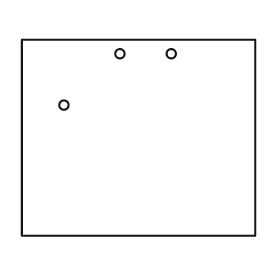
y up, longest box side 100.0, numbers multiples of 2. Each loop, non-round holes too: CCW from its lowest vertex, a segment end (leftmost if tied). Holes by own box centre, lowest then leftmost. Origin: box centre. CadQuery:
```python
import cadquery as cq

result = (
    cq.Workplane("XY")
    .moveTo(-50.0, -42.0)
    .lineTo(50.0, -42.0)
    .lineTo(50.0, 42.0)
    .lineTo(-50.0, 42.0)
    .close()
    .moveTo(-32.0, 14.0)
    .circle(2.0)
    .moveTo(-8.0, 36.0)
    .circle(2.0)
    .moveTo(14.0, 36.0)
    .circle(2.0)
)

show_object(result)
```